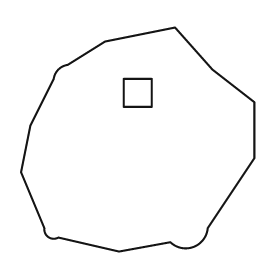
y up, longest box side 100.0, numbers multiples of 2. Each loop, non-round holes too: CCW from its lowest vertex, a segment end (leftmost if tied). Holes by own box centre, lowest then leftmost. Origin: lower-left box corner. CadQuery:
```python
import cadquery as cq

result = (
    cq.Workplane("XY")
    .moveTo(42.0, 0.0)
    .lineTo(64.0, 4.0)
    .threePointArc((74.0, 2.0), (80.0, 10.0))
    .lineTo(100.0, 40.0)
    .lineTo(100.0, 64.0)
    .lineTo(82.0, 78.0)
    .lineTo(66.0, 96.0)
    .lineTo(36.0, 90.0)
    .lineTo(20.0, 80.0)
    .threePointArc((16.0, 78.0), (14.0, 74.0))
    .lineTo(4.0, 54.0)
    .lineTo(0.0, 34.0)
    .lineTo(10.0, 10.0)
    .threePointArc((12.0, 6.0), (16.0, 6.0))
    .close()
    .moveTo(44.0, 62.0)
    .lineTo(56.0, 62.0)
    .lineTo(56.0, 74.0)
    .lineTo(44.0, 74.0)
    .close()
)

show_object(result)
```